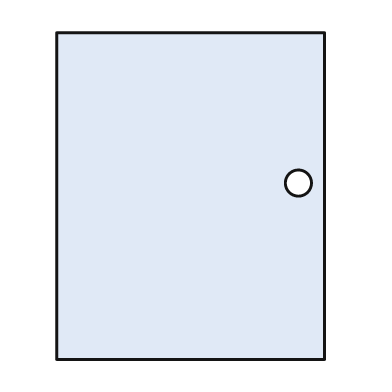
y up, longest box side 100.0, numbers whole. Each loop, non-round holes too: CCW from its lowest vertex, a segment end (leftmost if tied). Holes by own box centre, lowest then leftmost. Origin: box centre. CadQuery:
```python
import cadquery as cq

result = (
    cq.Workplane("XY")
    .moveTo(-41.0, -50.0)
    .lineTo(41.0, -50.0)
    .lineTo(41.0, 50.0)
    .lineTo(-41.0, 50.0)
    .close()
    .moveTo(33.0, 4.0)
    .circle(4.0)
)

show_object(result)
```